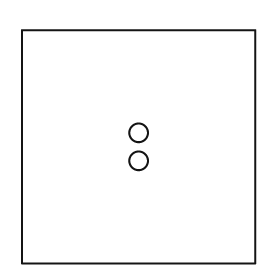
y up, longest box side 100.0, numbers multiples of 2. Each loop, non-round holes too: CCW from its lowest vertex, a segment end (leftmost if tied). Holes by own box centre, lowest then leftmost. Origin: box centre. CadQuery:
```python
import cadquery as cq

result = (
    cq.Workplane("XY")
    .moveTo(-50.0, -50.0)
    .lineTo(50.0, -50.0)
    .lineTo(50.0, 50.0)
    .lineTo(-50.0, 50.0)
    .close()
    .moveTo(0.0, -6.0)
    .circle(4.0)
    .moveTo(0.0, 6.0)
    .circle(4.0)
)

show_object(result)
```